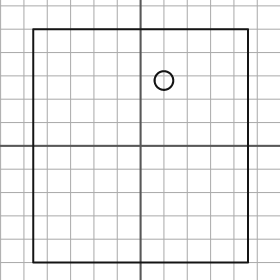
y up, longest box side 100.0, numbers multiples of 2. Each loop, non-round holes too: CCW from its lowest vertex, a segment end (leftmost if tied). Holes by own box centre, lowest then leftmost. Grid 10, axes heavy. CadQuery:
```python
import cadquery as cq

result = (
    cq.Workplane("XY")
    .moveTo(-46.0, -50.0)
    .lineTo(46.0, -50.0)
    .lineTo(46.0, 50.0)
    .lineTo(-46.0, 50.0)
    .close()
    .moveTo(10.0, 28.0)
    .circle(4.0)
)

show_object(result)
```